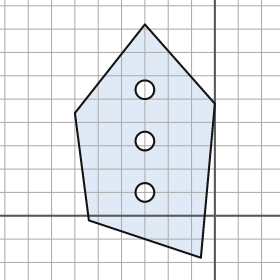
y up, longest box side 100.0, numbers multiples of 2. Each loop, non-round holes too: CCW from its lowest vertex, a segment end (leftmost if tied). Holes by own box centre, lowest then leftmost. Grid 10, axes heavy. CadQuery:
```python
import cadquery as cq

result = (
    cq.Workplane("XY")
    .moveTo(-6.0, -18.0)
    .lineTo(0.0, 48.0)
    .lineTo(-30.0, 82.0)
    .lineTo(-60.0, 44.0)
    .lineTo(-54.0, -2.0)
    .close()
    .moveTo(-30.0, 10.0)
    .circle(4.0)
    .moveTo(-30.0, 32.0)
    .circle(4.0)
    .moveTo(-30.0, 54.0)
    .circle(4.0)
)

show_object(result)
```